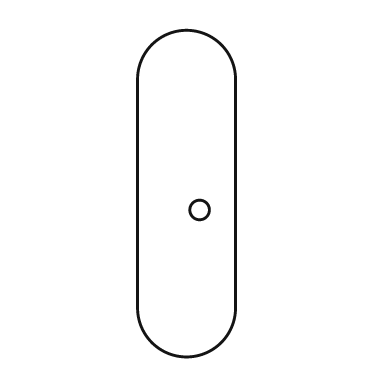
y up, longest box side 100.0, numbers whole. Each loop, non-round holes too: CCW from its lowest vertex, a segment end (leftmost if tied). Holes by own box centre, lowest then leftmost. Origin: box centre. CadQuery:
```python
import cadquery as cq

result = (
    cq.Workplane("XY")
    .moveTo(-15.0, -35.0)
    .threePointArc((0.0, -50.0), (15.0, -35.0))
    .lineTo(15.0, 35.0)
    .threePointArc((0.0, 50.0), (-15.0, 35.0))
    .close()
    .moveTo(4.0, -5.0)
    .circle(3.0)
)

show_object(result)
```